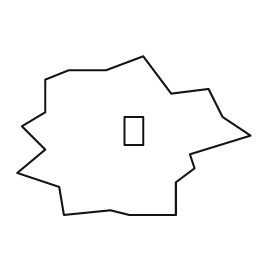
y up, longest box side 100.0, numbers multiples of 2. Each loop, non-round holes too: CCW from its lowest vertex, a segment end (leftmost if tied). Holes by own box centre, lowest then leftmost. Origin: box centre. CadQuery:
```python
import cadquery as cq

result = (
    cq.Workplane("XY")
    .moveTo(-30.0, -34.0)
    .lineTo(-10.0, -32.0)
    .lineTo(-2.0, -34.0)
    .lineTo(18.0, -34.0)
    .lineTo(18.0, -20.0)
    .lineTo(26.0, -14.0)
    .lineTo(24.0, -8.0)
    .lineTo(50.0, 0.0)
    .lineTo(38.0, 8.0)
    .lineTo(32.0, 20.0)
    .lineTo(16.0, 18.0)
    .lineTo(4.0, 34.0)
    .lineTo(-12.0, 28.0)
    .lineTo(-28.0, 28.0)
    .lineTo(-38.0, 24.0)
    .lineTo(-38.0, 10.0)
    .lineTo(-48.0, 4.0)
    .lineTo(-38.0, -6.0)
    .lineTo(-50.0, -16.0)
    .lineTo(-32.0, -22.0)
    .close()
    .moveTo(-4.0, -4.0)
    .lineTo(4.0, -4.0)
    .lineTo(4.0, 8.0)
    .lineTo(-4.0, 8.0)
    .close()
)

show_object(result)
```